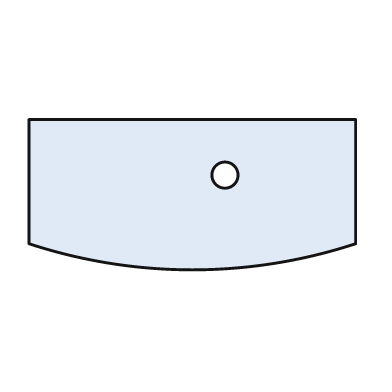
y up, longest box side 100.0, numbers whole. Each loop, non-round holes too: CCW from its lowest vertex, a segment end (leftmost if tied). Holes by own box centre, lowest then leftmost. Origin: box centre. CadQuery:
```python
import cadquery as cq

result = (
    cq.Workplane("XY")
    .moveTo(-50.0, -15.0)
    .threePointArc((0.0, -23.0), (50.0, -15.0))
    .lineTo(50.0, 23.0)
    .lineTo(-50.0, 23.0)
    .close()
    .moveTo(10.0, 6.0)
    .circle(4.0)
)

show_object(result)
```